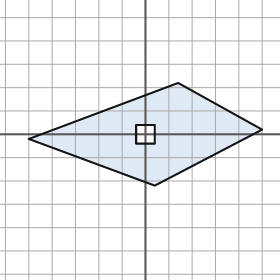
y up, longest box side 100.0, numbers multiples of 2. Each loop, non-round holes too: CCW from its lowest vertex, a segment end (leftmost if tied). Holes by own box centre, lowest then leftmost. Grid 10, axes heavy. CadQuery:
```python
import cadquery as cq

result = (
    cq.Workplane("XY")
    .moveTo(4.0, -22.0)
    .lineTo(50.0, 2.0)
    .lineTo(14.0, 22.0)
    .lineTo(-50.0, -2.0)
    .close()
    .moveTo(-4.0, -4.0)
    .lineTo(4.0, -4.0)
    .lineTo(4.0, 4.0)
    .lineTo(-4.0, 4.0)
    .close()
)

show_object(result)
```